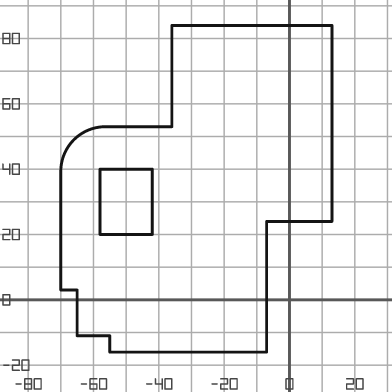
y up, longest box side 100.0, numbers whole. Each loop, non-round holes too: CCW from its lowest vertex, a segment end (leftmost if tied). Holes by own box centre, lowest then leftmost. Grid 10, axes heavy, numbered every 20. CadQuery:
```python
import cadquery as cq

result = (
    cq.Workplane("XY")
    .moveTo(-55.0, -16.0)
    .lineTo(-7.0, -16.0)
    .lineTo(-7.0, 24.0)
    .lineTo(13.0, 24.0)
    .lineTo(13.0, 84.0)
    .lineTo(-36.0, 84.0)
    .lineTo(-36.0, 53.0)
    .lineTo(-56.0, 53.0)
    .threePointArc((-66.0, 49.0), (-70.0, 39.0))
    .lineTo(-70.0, 3.0)
    .lineTo(-65.0, 3.0)
    .lineTo(-65.0, -11.0)
    .lineTo(-55.0, -11.0)
    .close()
    .moveTo(-58.0, 20.0)
    .lineTo(-42.0, 20.0)
    .lineTo(-42.0, 40.0)
    .lineTo(-58.0, 40.0)
    .close()
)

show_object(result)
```